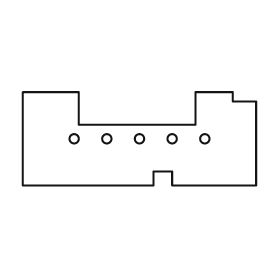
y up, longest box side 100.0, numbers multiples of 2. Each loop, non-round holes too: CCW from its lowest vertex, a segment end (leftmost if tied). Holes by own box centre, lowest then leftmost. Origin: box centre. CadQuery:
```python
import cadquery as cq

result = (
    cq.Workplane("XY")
    .moveTo(-50.0, -20.0)
    .lineTo(6.0, -20.0)
    .lineTo(6.0, -14.0)
    .lineTo(14.0, -14.0)
    .lineTo(14.0, -20.0)
    .lineTo(50.0, -20.0)
    .lineTo(50.0, 16.0)
    .lineTo(40.0, 16.0)
    .lineTo(40.0, 20.0)
    .lineTo(24.0, 20.0)
    .lineTo(24.0, 6.0)
    .lineTo(-26.0, 6.0)
    .lineTo(-26.0, 20.0)
    .lineTo(-50.0, 20.0)
    .close()
    .moveTo(-28.0, 0.0)
    .circle(2.0)
    .moveTo(-14.0, 0.0)
    .circle(2.0)
    .moveTo(0.0, 0.0)
    .circle(2.0)
    .moveTo(14.0, 0.0)
    .circle(2.0)
    .moveTo(28.0, 0.0)
    .circle(2.0)
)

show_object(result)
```